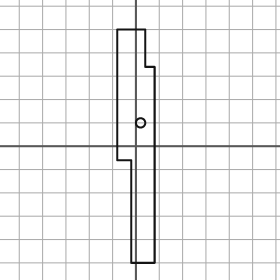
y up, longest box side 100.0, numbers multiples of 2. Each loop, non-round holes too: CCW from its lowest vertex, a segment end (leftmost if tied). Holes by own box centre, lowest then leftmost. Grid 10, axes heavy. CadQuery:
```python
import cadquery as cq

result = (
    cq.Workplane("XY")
    .moveTo(-2.0, -50.0)
    .lineTo(8.0, -50.0)
    .lineTo(8.0, 34.0)
    .lineTo(4.0, 34.0)
    .lineTo(4.0, 50.0)
    .lineTo(-8.0, 50.0)
    .lineTo(-8.0, -6.0)
    .lineTo(-2.0, -6.0)
    .close()
    .moveTo(2.0, 10.0)
    .circle(2.0)
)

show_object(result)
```